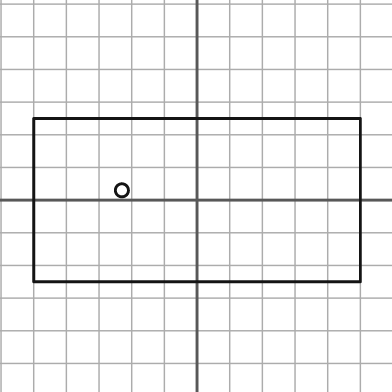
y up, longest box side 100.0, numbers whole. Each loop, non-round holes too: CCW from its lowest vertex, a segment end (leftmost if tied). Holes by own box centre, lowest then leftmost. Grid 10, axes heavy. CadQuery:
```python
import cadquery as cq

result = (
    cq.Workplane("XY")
    .moveTo(-50.0, -25.0)
    .lineTo(50.0, -25.0)
    .lineTo(50.0, 25.0)
    .lineTo(-50.0, 25.0)
    .close()
    .moveTo(-23.0, 3.0)
    .circle(2.0)
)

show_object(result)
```